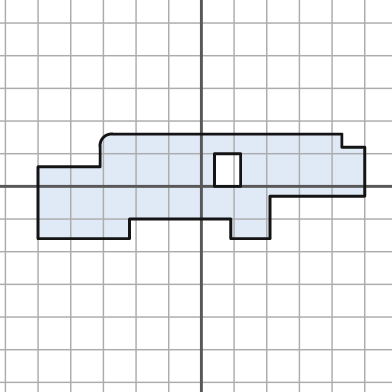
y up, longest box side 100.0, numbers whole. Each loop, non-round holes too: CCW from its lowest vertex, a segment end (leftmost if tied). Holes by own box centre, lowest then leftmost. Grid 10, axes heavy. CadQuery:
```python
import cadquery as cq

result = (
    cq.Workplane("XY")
    .moveTo(-50.0, -16.0)
    .lineTo(-22.0, -16.0)
    .lineTo(-22.0, -10.0)
    .lineTo(9.0, -10.0)
    .lineTo(9.0, -16.0)
    .lineTo(21.0, -16.0)
    .lineTo(21.0, -3.0)
    .lineTo(50.0, -3.0)
    .lineTo(50.0, 12.0)
    .lineTo(43.0, 12.0)
    .lineTo(43.0, 16.0)
    .lineTo(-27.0, 16.0)
    .threePointArc((-30.0, 15.0), (-31.0, 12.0))
    .lineTo(-31.0, 6.0)
    .lineTo(-50.0, 6.0)
    .close()
    .moveTo(4.0, 0.0)
    .lineTo(12.0, 0.0)
    .lineTo(12.0, 10.0)
    .lineTo(4.0, 10.0)
    .close()
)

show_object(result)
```